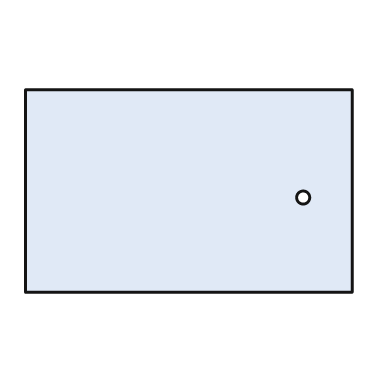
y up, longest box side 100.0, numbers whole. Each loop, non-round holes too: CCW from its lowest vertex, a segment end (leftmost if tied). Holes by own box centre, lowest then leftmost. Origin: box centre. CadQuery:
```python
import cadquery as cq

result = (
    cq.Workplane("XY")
    .moveTo(-50.0, -31.0)
    .lineTo(50.0, -31.0)
    .lineTo(50.0, 31.0)
    .lineTo(-50.0, 31.0)
    .close()
    .moveTo(35.0, -2.0)
    .circle(2.0)
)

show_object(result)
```